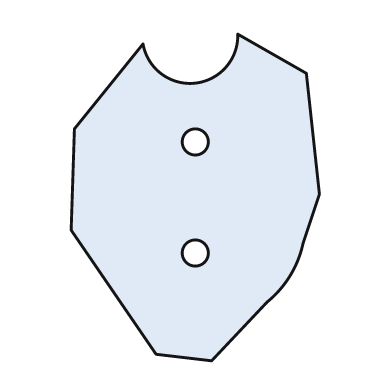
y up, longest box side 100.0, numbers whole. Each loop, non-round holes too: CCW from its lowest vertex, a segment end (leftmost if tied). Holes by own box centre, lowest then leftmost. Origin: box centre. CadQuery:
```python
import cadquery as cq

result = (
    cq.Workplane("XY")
    .moveTo(5.0, -50.0)
    .lineTo(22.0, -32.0)
    .threePointArc((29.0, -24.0), (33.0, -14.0))
    .lineTo(38.0, 1.0)
    .lineTo(34.0, 38.0)
    .lineTo(13.0, 50.0)
    .threePointArc((0.0, 35.0), (-16.0, 47.0))
    .lineTo(-37.0, 21.0)
    .lineTo(-38.0, -10.0)
    .lineTo(-12.0, -48.0)
    .close()
    .moveTo(0.0, -17.0)
    .circle(4.0)
    .moveTo(0.0, 17.0)
    .circle(4.0)
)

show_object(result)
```